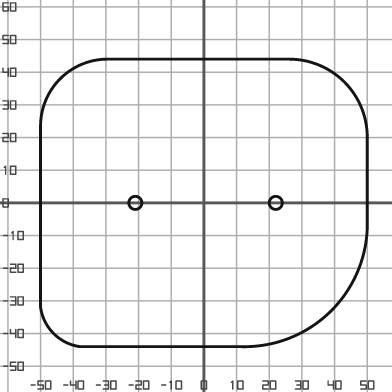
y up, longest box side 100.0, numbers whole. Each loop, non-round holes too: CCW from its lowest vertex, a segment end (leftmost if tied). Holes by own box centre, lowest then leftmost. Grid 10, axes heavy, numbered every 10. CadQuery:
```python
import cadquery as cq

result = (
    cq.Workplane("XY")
    .moveTo(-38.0, -44.0)
    .lineTo(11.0, -44.0)
    .threePointArc((39.0, -33.0), (50.0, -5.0))
    .lineTo(50.0, 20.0)
    .threePointArc((43.0, 37.0), (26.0, 44.0))
    .lineTo(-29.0, 44.0)
    .threePointArc((-44.0, 38.0), (-50.0, 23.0))
    .lineTo(-50.0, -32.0)
    .threePointArc((-46.0, -40.0), (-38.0, -44.0))
    .close()
    .moveTo(-21.0, 0.0)
    .circle(2.0)
    .moveTo(22.0, 0.0)
    .circle(2.0)
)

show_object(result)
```